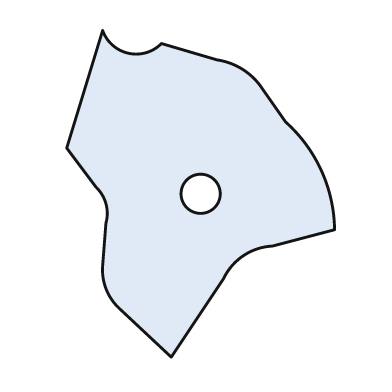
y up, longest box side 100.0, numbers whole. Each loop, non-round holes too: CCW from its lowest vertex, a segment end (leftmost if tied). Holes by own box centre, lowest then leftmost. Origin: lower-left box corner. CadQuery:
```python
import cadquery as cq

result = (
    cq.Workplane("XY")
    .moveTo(32.0, 0.0)
    .lineTo(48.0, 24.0)
    .threePointArc((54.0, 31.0), (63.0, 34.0))
    .lineTo(82.0, 39.0)
    .threePointArc((78.0, 57.0), (67.0, 72.0))
    .lineTo(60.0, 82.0)
    .threePointArc((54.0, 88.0), (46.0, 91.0))
    .lineTo(29.0, 96.0)
    .threePointArc((19.0, 93.0), (11.0, 100.0))
    .lineTo(0.0, 64.0)
    .lineTo(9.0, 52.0)
    .threePointArc((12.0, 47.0), (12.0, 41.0))
    .lineTo(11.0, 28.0)
    .threePointArc((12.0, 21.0), (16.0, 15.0))
    .close()
    .moveTo(41.0, 50.0)
    .circle(6.0)
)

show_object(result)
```